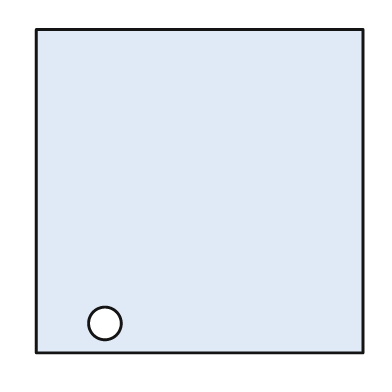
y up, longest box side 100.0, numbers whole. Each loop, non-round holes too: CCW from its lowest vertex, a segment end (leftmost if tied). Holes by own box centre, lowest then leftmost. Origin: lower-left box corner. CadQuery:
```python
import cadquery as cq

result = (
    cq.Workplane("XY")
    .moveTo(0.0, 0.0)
    .lineTo(100.0, 0.0)
    .lineTo(100.0, 99.0)
    .lineTo(0.0, 99.0)
    .close()
    .moveTo(21.0, 9.0)
    .circle(5.0)
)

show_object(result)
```